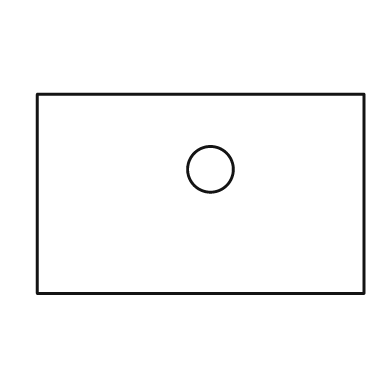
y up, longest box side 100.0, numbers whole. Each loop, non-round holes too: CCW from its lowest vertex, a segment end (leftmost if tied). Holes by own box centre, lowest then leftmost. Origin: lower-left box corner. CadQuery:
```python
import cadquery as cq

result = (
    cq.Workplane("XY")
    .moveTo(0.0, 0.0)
    .lineTo(100.0, 0.0)
    .lineTo(100.0, 61.0)
    .lineTo(0.0, 61.0)
    .close()
    .moveTo(53.0, 38.0)
    .circle(7.0)
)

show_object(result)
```